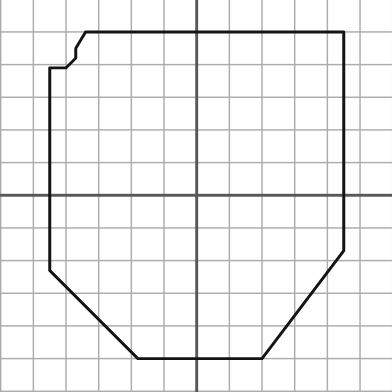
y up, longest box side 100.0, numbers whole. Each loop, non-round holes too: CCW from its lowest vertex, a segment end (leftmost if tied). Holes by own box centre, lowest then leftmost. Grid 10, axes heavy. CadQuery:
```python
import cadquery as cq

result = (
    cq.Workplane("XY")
    .moveTo(-18.0, -50.0)
    .lineTo(20.0, -50.0)
    .lineTo(45.0, -17.0)
    .lineTo(45.0, 50.0)
    .lineTo(-34.0, 50.0)
    .lineTo(-37.0, 45.0)
    .lineTo(-37.0, 42.0)
    .lineTo(-40.0, 39.0)
    .lineTo(-45.0, 39.0)
    .lineTo(-45.0, -23.0)
    .close()
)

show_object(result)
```